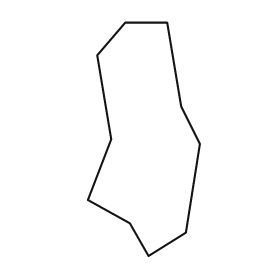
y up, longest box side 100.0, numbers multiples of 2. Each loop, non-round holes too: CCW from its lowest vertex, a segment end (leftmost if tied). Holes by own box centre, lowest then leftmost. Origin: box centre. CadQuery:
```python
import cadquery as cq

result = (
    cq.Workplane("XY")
    .moveTo(2.0, -50.0)
    .lineTo(18.0, -40.0)
    .lineTo(24.0, -2.0)
    .lineTo(16.0, 14.0)
    .lineTo(10.0, 50.0)
    .lineTo(-8.0, 50.0)
    .lineTo(-20.0, 36.0)
    .lineTo(-14.0, 0.0)
    .lineTo(-24.0, -26.0)
    .lineTo(-6.0, -36.0)
    .close()
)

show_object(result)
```